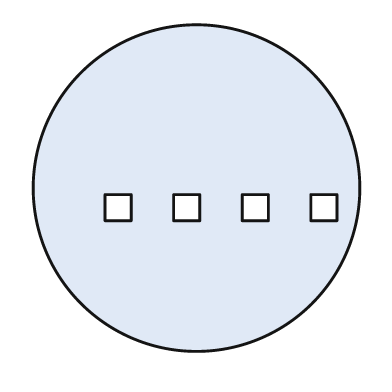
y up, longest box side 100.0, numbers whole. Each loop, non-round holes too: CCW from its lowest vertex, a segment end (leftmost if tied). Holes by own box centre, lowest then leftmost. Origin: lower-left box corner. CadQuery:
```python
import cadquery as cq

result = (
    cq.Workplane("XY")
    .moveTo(50.0, 50.0)
    .circle(50.0)
    .moveTo(22.0, 40.0)
    .lineTo(30.0, 40.0)
    .lineTo(30.0, 48.0)
    .lineTo(22.0, 48.0)
    .close()
    .moveTo(43.0, 40.0)
    .lineTo(51.0, 40.0)
    .lineTo(51.0, 48.0)
    .lineTo(43.0, 48.0)
    .close()
    .moveTo(64.0, 40.0)
    .lineTo(72.0, 40.0)
    .lineTo(72.0, 48.0)
    .lineTo(64.0, 48.0)
    .close()
    .moveTo(85.0, 40.0)
    .lineTo(93.0, 40.0)
    .lineTo(93.0, 48.0)
    .lineTo(85.0, 48.0)
    .close()
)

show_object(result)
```